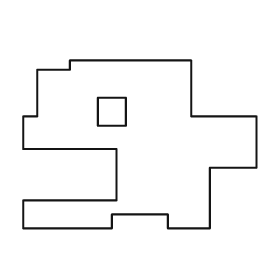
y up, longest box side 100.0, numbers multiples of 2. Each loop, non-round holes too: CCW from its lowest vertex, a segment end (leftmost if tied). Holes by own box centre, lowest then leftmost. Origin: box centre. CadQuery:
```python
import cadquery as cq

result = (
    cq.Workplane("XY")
    .moveTo(-50.0, -36.0)
    .lineTo(-12.0, -36.0)
    .lineTo(-12.0, -30.0)
    .lineTo(12.0, -30.0)
    .lineTo(12.0, -36.0)
    .lineTo(30.0, -36.0)
    .lineTo(30.0, -10.0)
    .lineTo(50.0, -10.0)
    .lineTo(50.0, 12.0)
    .lineTo(22.0, 12.0)
    .lineTo(22.0, 36.0)
    .lineTo(-30.0, 36.0)
    .lineTo(-30.0, 32.0)
    .lineTo(-44.0, 32.0)
    .lineTo(-44.0, 12.0)
    .lineTo(-50.0, 12.0)
    .lineTo(-50.0, -2.0)
    .lineTo(-10.0, -2.0)
    .lineTo(-10.0, -24.0)
    .lineTo(-50.0, -24.0)
    .close()
    .moveTo(-18.0, 8.0)
    .lineTo(-6.0, 8.0)
    .lineTo(-6.0, 20.0)
    .lineTo(-18.0, 20.0)
    .close()
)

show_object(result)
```